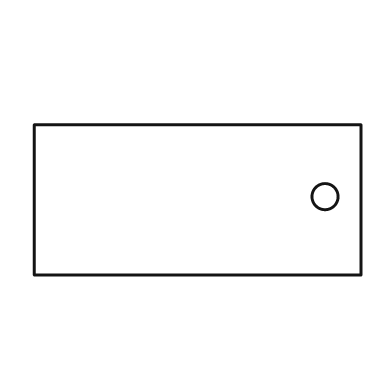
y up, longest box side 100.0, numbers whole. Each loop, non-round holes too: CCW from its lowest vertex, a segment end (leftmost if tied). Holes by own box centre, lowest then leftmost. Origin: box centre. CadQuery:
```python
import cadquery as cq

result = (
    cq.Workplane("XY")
    .moveTo(-50.0, -23.0)
    .lineTo(50.0, -23.0)
    .lineTo(50.0, 23.0)
    .lineTo(-50.0, 23.0)
    .close()
    .moveTo(39.0, 1.0)
    .circle(4.0)
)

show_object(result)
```